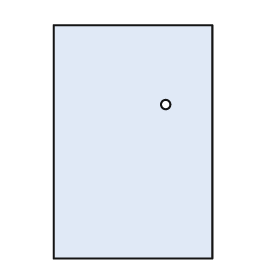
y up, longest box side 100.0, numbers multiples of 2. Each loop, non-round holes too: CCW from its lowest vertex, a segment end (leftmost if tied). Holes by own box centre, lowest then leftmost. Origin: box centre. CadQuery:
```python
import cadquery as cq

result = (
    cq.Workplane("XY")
    .moveTo(-34.0, -50.0)
    .lineTo(34.0, -50.0)
    .lineTo(34.0, 50.0)
    .lineTo(-34.0, 50.0)
    .close()
    .moveTo(14.0, 16.0)
    .circle(2.0)
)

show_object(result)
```